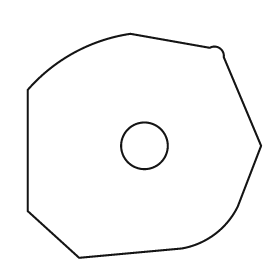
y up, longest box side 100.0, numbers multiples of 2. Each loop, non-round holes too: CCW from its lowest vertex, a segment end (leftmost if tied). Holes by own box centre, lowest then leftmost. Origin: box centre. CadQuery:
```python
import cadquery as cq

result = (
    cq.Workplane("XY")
    .moveTo(-28.0, -48.0)
    .lineTo(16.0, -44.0)
    .threePointArc((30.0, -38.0), (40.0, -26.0))
    .lineTo(50.0, 0.0)
    .lineTo(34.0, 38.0)
    .threePointArc((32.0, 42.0), (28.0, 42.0))
    .lineTo(-6.0, 48.0)
    .threePointArc((-30.0, 40.0), (-50.0, 24.0))
    .lineTo(-50.0, -28.0)
    .close()
    .moveTo(0.0, 0.0)
    .circle(10.0)
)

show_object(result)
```